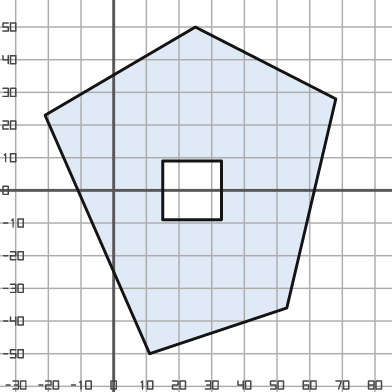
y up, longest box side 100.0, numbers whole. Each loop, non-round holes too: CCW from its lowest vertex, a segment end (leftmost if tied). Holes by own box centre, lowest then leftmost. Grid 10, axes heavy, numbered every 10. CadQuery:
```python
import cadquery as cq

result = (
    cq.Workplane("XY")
    .moveTo(11.0, -50.0)
    .lineTo(53.0, -36.0)
    .lineTo(68.0, 28.0)
    .lineTo(25.0, 50.0)
    .lineTo(-21.0, 23.0)
    .close()
    .moveTo(15.0, -9.0)
    .lineTo(33.0, -9.0)
    .lineTo(33.0, 9.0)
    .lineTo(15.0, 9.0)
    .close()
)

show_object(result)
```